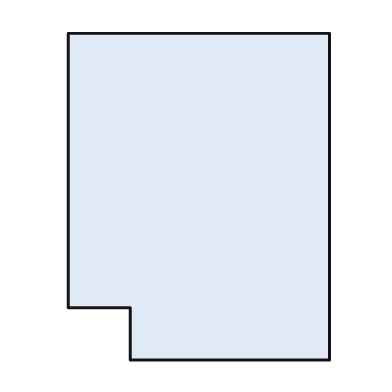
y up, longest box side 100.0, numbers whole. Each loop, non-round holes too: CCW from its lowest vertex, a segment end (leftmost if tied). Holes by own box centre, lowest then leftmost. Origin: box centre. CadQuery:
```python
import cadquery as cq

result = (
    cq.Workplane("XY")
    .moveTo(-21.0, -50.0)
    .lineTo(40.0, -50.0)
    .lineTo(40.0, 50.0)
    .lineTo(-40.0, 50.0)
    .lineTo(-40.0, -34.0)
    .lineTo(-21.0, -34.0)
    .close()
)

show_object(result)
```